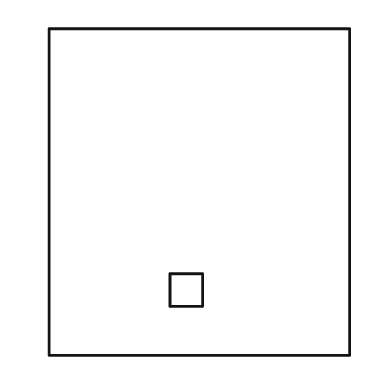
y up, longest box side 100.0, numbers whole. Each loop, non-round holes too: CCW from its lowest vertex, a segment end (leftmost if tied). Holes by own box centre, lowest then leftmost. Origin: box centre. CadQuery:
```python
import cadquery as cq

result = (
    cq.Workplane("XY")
    .moveTo(-46.0, -50.0)
    .lineTo(46.0, -50.0)
    .lineTo(46.0, 50.0)
    .lineTo(-46.0, 50.0)
    .close()
    .moveTo(-9.0, -35.0)
    .lineTo(1.0, -35.0)
    .lineTo(1.0, -25.0)
    .lineTo(-9.0, -25.0)
    .close()
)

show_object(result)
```